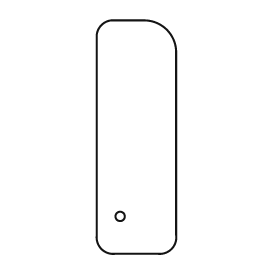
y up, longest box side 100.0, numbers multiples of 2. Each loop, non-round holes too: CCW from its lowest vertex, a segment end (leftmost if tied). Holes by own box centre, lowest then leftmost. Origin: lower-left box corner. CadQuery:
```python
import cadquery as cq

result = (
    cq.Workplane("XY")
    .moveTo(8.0, 0.0)
    .lineTo(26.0, 0.0)
    .threePointArc((32.0, 2.0), (34.0, 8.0))
    .lineTo(34.0, 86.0)
    .threePointArc((30.0, 96.0), (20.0, 100.0))
    .lineTo(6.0, 100.0)
    .threePointArc((2.0, 98.0), (0.0, 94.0))
    .lineTo(0.0, 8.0)
    .threePointArc((2.0, 2.0), (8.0, 0.0))
    .close()
    .moveTo(10.0, 16.0)
    .circle(2.0)
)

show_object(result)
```